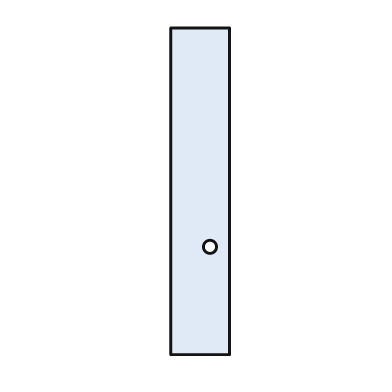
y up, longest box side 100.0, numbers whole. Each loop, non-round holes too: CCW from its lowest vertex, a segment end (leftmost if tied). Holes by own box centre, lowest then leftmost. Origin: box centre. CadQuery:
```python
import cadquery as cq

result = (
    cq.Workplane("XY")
    .moveTo(-9.0, -50.0)
    .lineTo(9.0, -50.0)
    .lineTo(9.0, 50.0)
    .lineTo(-9.0, 50.0)
    .close()
    .moveTo(3.0, -17.0)
    .circle(2.0)
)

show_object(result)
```